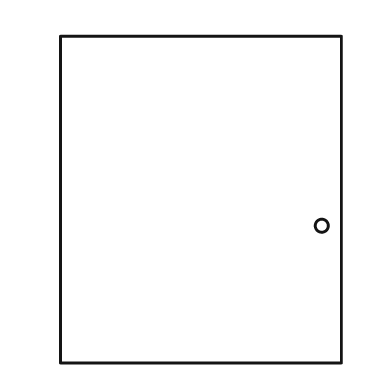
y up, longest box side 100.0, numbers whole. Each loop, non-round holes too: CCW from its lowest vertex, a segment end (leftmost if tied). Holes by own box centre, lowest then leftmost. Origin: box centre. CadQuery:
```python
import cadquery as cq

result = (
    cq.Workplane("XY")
    .moveTo(-43.0, -50.0)
    .lineTo(43.0, -50.0)
    .lineTo(43.0, 50.0)
    .lineTo(-43.0, 50.0)
    .close()
    .moveTo(37.0, -8.0)
    .circle(2.0)
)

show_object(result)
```